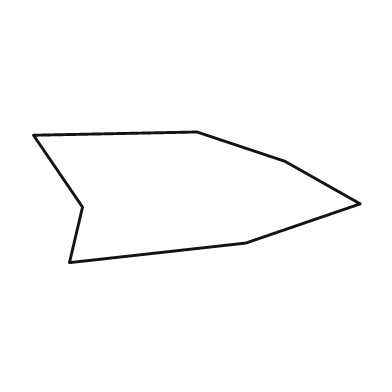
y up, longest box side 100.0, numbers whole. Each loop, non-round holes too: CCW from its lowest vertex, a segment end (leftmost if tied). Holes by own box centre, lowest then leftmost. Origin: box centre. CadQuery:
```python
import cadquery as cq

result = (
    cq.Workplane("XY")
    .moveTo(-39.0, -20.0)
    .lineTo(15.0, -14.0)
    .lineTo(50.0, -2.0)
    .lineTo(27.0, 11.0)
    .lineTo(0.0, 20.0)
    .lineTo(-50.0, 19.0)
    .lineTo(-35.0, -3.0)
    .close()
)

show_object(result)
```